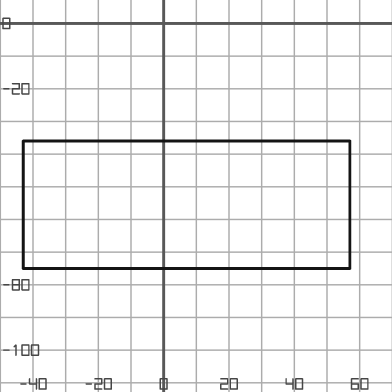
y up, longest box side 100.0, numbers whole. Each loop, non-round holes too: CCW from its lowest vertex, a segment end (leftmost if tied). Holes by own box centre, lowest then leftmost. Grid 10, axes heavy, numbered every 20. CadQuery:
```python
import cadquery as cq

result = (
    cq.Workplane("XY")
    .moveTo(-43.0, -75.0)
    .lineTo(57.0, -75.0)
    .lineTo(57.0, -36.0)
    .lineTo(-43.0, -36.0)
    .close()
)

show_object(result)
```